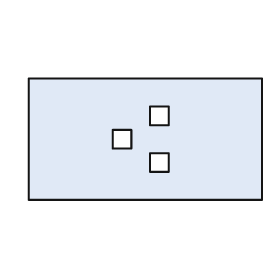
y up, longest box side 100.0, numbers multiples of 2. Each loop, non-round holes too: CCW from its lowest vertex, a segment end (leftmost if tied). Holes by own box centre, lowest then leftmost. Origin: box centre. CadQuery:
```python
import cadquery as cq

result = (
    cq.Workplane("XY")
    .moveTo(-50.0, -26.0)
    .lineTo(50.0, -26.0)
    .lineTo(50.0, 26.0)
    .lineTo(-50.0, 26.0)
    .close()
    .moveTo(2.0, -14.0)
    .lineTo(10.0, -14.0)
    .lineTo(10.0, -6.0)
    .lineTo(2.0, -6.0)
    .close()
    .moveTo(-14.0, -4.0)
    .lineTo(-6.0, -4.0)
    .lineTo(-6.0, 4.0)
    .lineTo(-14.0, 4.0)
    .close()
    .moveTo(2.0, 6.0)
    .lineTo(10.0, 6.0)
    .lineTo(10.0, 14.0)
    .lineTo(2.0, 14.0)
    .close()
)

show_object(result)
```